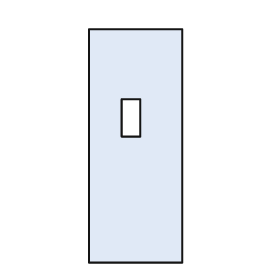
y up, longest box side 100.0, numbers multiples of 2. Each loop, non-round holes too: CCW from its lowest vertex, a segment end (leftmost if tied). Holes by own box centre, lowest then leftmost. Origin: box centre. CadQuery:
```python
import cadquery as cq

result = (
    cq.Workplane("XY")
    .moveTo(-20.0, -50.0)
    .lineTo(20.0, -50.0)
    .lineTo(20.0, 50.0)
    .lineTo(-20.0, 50.0)
    .close()
    .moveTo(-6.0, 4.0)
    .lineTo(2.0, 4.0)
    .lineTo(2.0, 20.0)
    .lineTo(-6.0, 20.0)
    .close()
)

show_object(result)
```